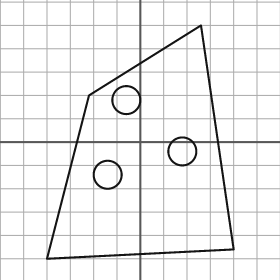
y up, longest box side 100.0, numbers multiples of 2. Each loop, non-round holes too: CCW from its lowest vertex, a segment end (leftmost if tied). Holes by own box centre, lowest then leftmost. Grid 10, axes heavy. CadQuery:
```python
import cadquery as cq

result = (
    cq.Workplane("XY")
    .moveTo(-40.0, -50.0)
    .lineTo(40.0, -46.0)
    .lineTo(26.0, 50.0)
    .lineTo(-22.0, 20.0)
    .close()
    .moveTo(-14.0, -14.0)
    .circle(6.0)
    .moveTo(18.0, -4.0)
    .circle(6.0)
    .moveTo(-6.0, 18.0)
    .circle(6.0)
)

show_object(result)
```